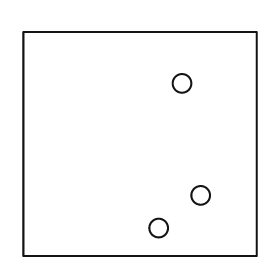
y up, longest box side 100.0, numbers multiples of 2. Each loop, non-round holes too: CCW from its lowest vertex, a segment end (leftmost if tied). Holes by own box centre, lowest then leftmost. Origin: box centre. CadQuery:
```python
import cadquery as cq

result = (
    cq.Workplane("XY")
    .moveTo(-50.0, -48.0)
    .lineTo(50.0, -48.0)
    .lineTo(50.0, 48.0)
    .lineTo(-50.0, 48.0)
    .close()
    .moveTo(8.0, -36.0)
    .circle(4.0)
    .moveTo(26.0, -22.0)
    .circle(4.0)
    .moveTo(18.0, 26.0)
    .circle(4.0)
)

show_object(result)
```